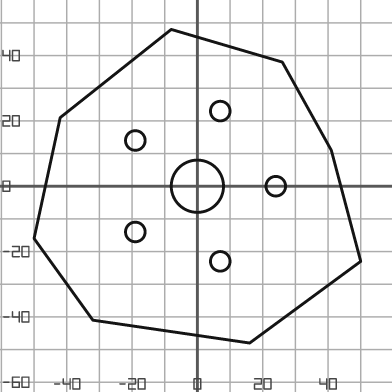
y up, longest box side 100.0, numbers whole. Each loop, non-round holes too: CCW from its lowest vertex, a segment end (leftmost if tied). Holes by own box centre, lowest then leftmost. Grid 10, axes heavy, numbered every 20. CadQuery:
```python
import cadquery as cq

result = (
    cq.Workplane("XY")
    .moveTo(16.0, -48.0)
    .lineTo(50.0, -23.0)
    .lineTo(41.0, 11.0)
    .lineTo(26.0, 38.0)
    .lineTo(-8.0, 48.0)
    .lineTo(-42.0, 21.0)
    .lineTo(-50.0, -16.0)
    .lineTo(-32.0, -41.0)
    .close()
    .moveTo(7.0, -23.0)
    .circle(3.0)
    .moveTo(-19.0, -14.0)
    .circle(3.0)
    .moveTo(0.0, 0.0)
    .circle(8.0)
    .moveTo(24.0, 0.0)
    .circle(3.0)
    .moveTo(-19.0, 14.0)
    .circle(3.0)
    .moveTo(7.0, 23.0)
    .circle(3.0)
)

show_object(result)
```